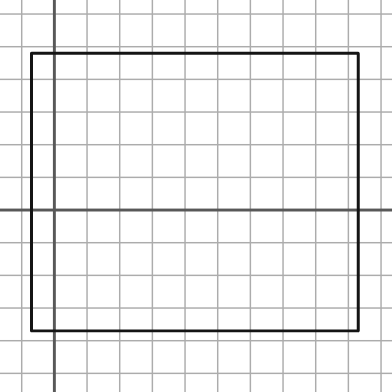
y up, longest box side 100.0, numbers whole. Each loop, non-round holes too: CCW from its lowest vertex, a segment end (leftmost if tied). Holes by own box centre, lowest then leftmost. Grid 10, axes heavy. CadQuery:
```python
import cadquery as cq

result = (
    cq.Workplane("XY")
    .moveTo(-7.0, -37.0)
    .lineTo(93.0, -37.0)
    .lineTo(93.0, 48.0)
    .lineTo(-7.0, 48.0)
    .close()
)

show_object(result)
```